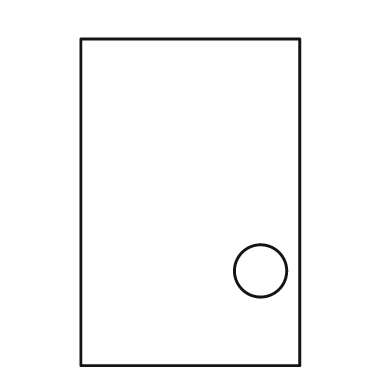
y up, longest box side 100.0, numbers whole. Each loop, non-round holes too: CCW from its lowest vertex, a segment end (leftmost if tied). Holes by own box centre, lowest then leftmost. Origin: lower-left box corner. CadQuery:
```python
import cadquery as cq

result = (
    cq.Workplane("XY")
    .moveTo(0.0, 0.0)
    .lineTo(67.0, 0.0)
    .lineTo(67.0, 100.0)
    .lineTo(0.0, 100.0)
    .close()
    .moveTo(55.0, 29.0)
    .circle(8.0)
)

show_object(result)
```